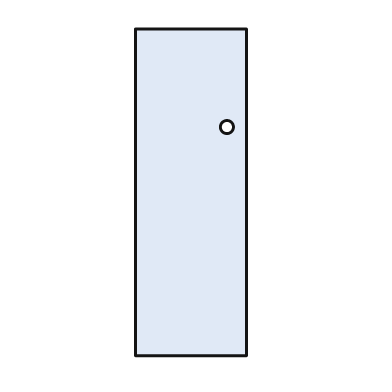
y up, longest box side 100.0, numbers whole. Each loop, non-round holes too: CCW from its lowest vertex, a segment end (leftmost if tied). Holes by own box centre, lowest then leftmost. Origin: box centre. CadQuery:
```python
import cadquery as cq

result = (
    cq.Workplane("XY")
    .moveTo(-17.0, -50.0)
    .lineTo(17.0, -50.0)
    .lineTo(17.0, 50.0)
    .lineTo(-17.0, 50.0)
    .close()
    .moveTo(11.0, 20.0)
    .circle(2.0)
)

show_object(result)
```